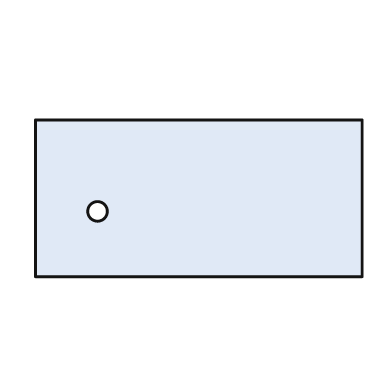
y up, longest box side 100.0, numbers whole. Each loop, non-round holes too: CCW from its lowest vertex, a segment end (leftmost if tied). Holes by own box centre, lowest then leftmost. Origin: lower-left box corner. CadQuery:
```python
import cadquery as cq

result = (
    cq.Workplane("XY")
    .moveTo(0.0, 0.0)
    .lineTo(100.0, 0.0)
    .lineTo(100.0, 48.0)
    .lineTo(0.0, 48.0)
    .close()
    .moveTo(19.0, 20.0)
    .circle(3.0)
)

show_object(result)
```